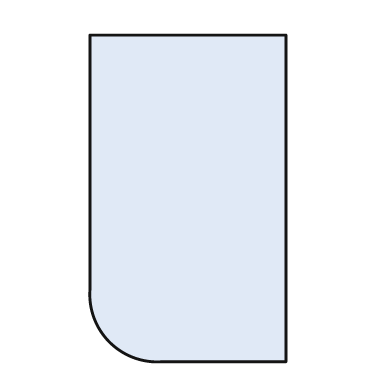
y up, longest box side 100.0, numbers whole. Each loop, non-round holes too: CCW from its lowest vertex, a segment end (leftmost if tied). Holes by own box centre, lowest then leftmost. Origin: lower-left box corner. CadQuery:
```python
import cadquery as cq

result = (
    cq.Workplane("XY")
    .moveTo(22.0, 0.0)
    .lineTo(60.0, 0.0)
    .lineTo(60.0, 100.0)
    .lineTo(0.0, 100.0)
    .lineTo(0.0, 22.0)
    .threePointArc((6.0, 6.0), (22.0, 0.0))
    .close()
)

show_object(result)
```